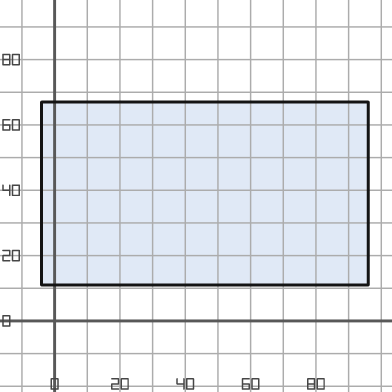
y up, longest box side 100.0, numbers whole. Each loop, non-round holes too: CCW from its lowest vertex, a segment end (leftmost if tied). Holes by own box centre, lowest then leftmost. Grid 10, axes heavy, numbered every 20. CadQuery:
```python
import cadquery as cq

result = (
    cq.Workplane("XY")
    .moveTo(-4.0, 11.0)
    .lineTo(96.0, 11.0)
    .lineTo(96.0, 67.0)
    .lineTo(-4.0, 67.0)
    .close()
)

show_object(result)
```